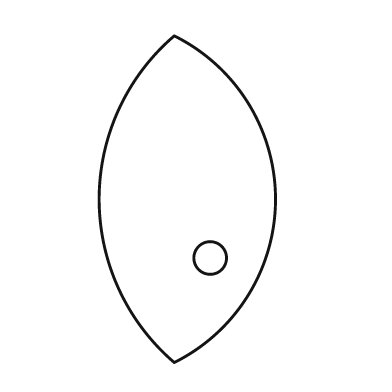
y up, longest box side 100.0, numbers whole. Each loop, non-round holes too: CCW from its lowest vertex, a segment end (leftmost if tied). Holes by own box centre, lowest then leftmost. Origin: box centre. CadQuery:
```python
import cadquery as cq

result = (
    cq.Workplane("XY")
    .moveTo(-4.0, -50.0)
    .threePointArc((27.0, 0.0), (-4.0, 50.0))
    .threePointArc((-27.0, 0.0), (-4.0, -50.0))
    .close()
    .moveTo(7.0, -18.0)
    .circle(5.0)
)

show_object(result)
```